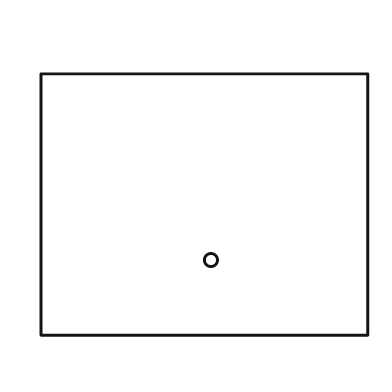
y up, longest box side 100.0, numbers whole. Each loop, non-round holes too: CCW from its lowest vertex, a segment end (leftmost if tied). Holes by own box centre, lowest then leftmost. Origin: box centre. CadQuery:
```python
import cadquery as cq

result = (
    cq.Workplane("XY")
    .moveTo(-50.0, -40.0)
    .lineTo(50.0, -40.0)
    .lineTo(50.0, 40.0)
    .lineTo(-50.0, 40.0)
    .close()
    .moveTo(2.0, -17.0)
    .circle(2.0)
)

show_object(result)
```